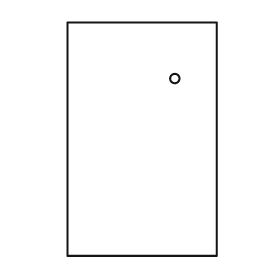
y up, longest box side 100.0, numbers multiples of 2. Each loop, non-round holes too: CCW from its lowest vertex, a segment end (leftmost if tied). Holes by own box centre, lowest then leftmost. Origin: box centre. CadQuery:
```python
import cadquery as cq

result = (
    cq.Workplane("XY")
    .moveTo(-32.0, -50.0)
    .lineTo(32.0, -50.0)
    .lineTo(32.0, 50.0)
    .lineTo(-32.0, 50.0)
    .close()
    .moveTo(14.0, 26.0)
    .circle(2.0)
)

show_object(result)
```